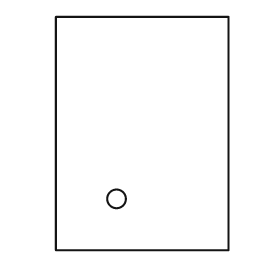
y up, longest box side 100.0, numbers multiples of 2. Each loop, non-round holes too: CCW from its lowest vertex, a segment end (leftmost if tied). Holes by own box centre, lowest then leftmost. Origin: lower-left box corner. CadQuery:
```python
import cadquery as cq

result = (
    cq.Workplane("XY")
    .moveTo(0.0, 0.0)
    .lineTo(74.0, 0.0)
    .lineTo(74.0, 100.0)
    .lineTo(0.0, 100.0)
    .close()
    .moveTo(26.0, 22.0)
    .circle(4.0)
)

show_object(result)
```